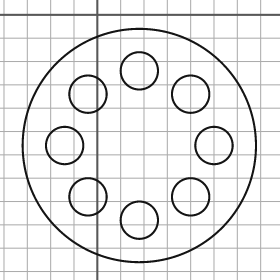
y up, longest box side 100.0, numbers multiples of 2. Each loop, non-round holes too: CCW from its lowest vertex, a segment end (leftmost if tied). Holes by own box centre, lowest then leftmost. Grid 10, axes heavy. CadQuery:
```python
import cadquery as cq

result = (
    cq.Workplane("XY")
    .moveTo(18.0, -56.0)
    .circle(50.0)
    .moveTo(18.0, -88.0)
    .circle(8.0)
    .moveTo(-4.0, -78.0)
    .circle(8.0)
    .moveTo(40.0, -78.0)
    .circle(8.0)
    .moveTo(-14.0, -56.0)
    .circle(8.0)
    .moveTo(50.0, -56.0)
    .circle(8.0)
    .moveTo(-4.0, -34.0)
    .circle(8.0)
    .moveTo(40.0, -34.0)
    .circle(8.0)
    .moveTo(18.0, -24.0)
    .circle(8.0)
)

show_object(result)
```